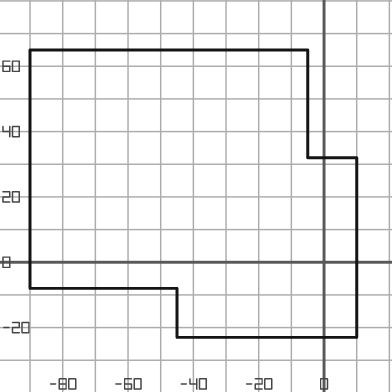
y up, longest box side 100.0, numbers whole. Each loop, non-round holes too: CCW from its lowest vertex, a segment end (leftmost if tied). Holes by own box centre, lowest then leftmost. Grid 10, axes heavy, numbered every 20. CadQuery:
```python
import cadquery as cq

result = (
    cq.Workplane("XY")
    .moveTo(-45.0, -23.0)
    .lineTo(10.0, -23.0)
    .lineTo(10.0, 32.0)
    .lineTo(-5.0, 32.0)
    .lineTo(-5.0, 65.0)
    .lineTo(-90.0, 65.0)
    .lineTo(-90.0, -8.0)
    .lineTo(-45.0, -8.0)
    .close()
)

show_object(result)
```